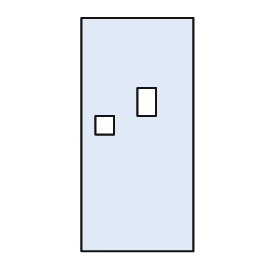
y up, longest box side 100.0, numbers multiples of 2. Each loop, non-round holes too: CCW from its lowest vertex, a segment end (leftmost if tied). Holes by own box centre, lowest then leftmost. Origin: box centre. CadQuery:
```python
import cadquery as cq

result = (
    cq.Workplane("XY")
    .moveTo(-24.0, -50.0)
    .lineTo(24.0, -50.0)
    .lineTo(24.0, 50.0)
    .lineTo(-24.0, 50.0)
    .close()
    .moveTo(-18.0, 0.0)
    .lineTo(-10.0, 0.0)
    .lineTo(-10.0, 8.0)
    .lineTo(-18.0, 8.0)
    .close()
    .moveTo(0.0, 8.0)
    .lineTo(8.0, 8.0)
    .lineTo(8.0, 20.0)
    .lineTo(0.0, 20.0)
    .close()
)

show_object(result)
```